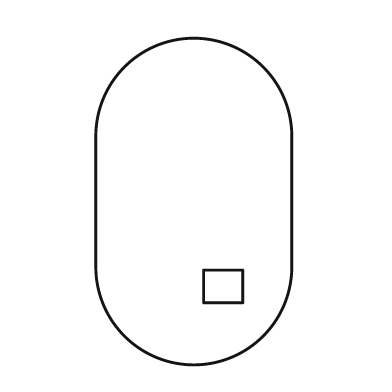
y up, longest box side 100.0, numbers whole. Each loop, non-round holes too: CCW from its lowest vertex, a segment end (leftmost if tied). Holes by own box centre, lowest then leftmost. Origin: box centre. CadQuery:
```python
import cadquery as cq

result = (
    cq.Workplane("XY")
    .moveTo(-30.0, -20.0)
    .threePointArc((0.0, -50.0), (30.0, -20.0))
    .lineTo(30.0, 20.0)
    .threePointArc((0.0, 50.0), (-30.0, 20.0))
    .close()
    .moveTo(3.0, -31.0)
    .lineTo(15.0, -31.0)
    .lineTo(15.0, -21.0)
    .lineTo(3.0, -21.0)
    .close()
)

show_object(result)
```